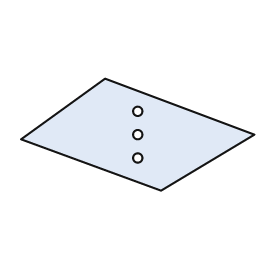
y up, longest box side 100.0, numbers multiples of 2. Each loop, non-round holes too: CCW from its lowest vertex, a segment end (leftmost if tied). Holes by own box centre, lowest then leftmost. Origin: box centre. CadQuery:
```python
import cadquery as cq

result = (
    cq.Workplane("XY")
    .moveTo(10.0, -24.0)
    .lineTo(50.0, 0.0)
    .lineTo(-14.0, 24.0)
    .lineTo(-50.0, -2.0)
    .close()
    .moveTo(0.0, -10.0)
    .circle(2.0)
    .moveTo(0.0, 0.0)
    .circle(2.0)
    .moveTo(0.0, 10.0)
    .circle(2.0)
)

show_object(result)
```